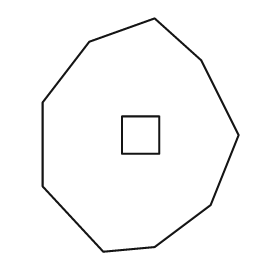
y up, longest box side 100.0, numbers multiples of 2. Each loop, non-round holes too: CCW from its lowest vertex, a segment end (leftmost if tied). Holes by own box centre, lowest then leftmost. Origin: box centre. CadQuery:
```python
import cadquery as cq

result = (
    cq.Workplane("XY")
    .moveTo(-16.0, -50.0)
    .lineTo(6.0, -48.0)
    .lineTo(30.0, -30.0)
    .lineTo(42.0, 0.0)
    .lineTo(26.0, 32.0)
    .lineTo(6.0, 50.0)
    .lineTo(-22.0, 40.0)
    .lineTo(-42.0, 14.0)
    .lineTo(-42.0, -22.0)
    .close()
    .moveTo(-8.0, -8.0)
    .lineTo(8.0, -8.0)
    .lineTo(8.0, 8.0)
    .lineTo(-8.0, 8.0)
    .close()
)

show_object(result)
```